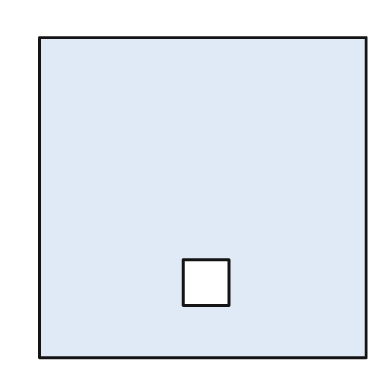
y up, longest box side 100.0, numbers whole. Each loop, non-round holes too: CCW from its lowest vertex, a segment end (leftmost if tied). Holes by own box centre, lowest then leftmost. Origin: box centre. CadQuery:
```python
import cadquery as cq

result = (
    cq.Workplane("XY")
    .moveTo(-50.0, -49.0)
    .lineTo(50.0, -49.0)
    .lineTo(50.0, 49.0)
    .lineTo(-50.0, 49.0)
    .close()
    .moveTo(-6.0, -33.0)
    .lineTo(8.0, -33.0)
    .lineTo(8.0, -19.0)
    .lineTo(-6.0, -19.0)
    .close()
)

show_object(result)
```